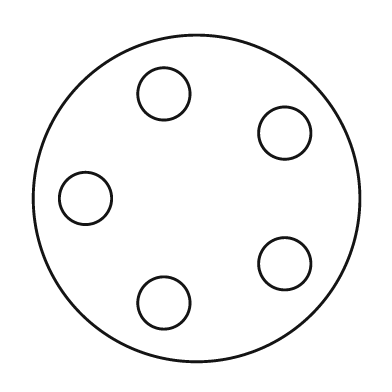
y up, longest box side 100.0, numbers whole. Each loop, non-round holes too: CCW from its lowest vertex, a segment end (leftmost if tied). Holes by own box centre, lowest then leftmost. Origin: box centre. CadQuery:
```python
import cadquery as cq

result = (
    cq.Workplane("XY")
    .moveTo(0.0, 0.0)
    .circle(50.0)
    .moveTo(-10.0, -32.0)
    .circle(8.0)
    .moveTo(27.0, -20.0)
    .circle(8.0)
    .moveTo(-34.0, 0.0)
    .circle(8.0)
    .moveTo(27.0, 20.0)
    .circle(8.0)
    .moveTo(-10.0, 32.0)
    .circle(8.0)
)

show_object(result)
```